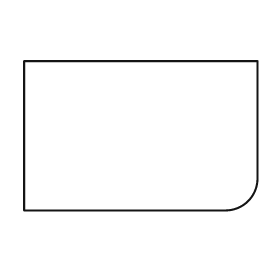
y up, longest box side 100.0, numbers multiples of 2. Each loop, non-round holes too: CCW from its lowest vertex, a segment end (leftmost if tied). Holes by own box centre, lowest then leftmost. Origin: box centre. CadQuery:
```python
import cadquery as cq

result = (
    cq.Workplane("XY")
    .moveTo(-50.0, -32.0)
    .lineTo(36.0, -32.0)
    .threePointArc((46.0, -28.0), (50.0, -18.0))
    .lineTo(50.0, 32.0)
    .lineTo(-50.0, 32.0)
    .close()
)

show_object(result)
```